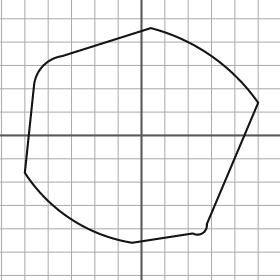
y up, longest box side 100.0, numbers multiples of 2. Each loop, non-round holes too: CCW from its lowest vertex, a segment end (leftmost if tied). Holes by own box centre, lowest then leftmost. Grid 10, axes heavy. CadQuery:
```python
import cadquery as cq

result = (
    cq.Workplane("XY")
    .moveTo(-4.0, -46.0)
    .lineTo(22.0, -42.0)
    .threePointArc((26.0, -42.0), (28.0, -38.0))
    .lineTo(50.0, 14.0)
    .threePointArc((30.0, 34.0), (4.0, 46.0))
    .lineTo(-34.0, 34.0)
    .threePointArc((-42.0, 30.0), (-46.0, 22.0))
    .lineTo(-50.0, -16.0)
    .threePointArc((-30.0, -36.0), (-4.0, -46.0))
    .close()
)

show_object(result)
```